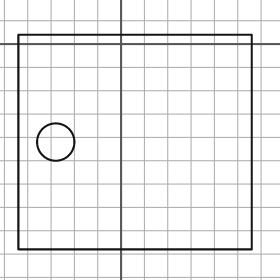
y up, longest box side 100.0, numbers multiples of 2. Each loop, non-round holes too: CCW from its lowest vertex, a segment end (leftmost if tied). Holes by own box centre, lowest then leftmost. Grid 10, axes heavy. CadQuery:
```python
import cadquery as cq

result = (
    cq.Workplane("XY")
    .moveTo(-44.0, -88.0)
    .lineTo(56.0, -88.0)
    .lineTo(56.0, 4.0)
    .lineTo(-44.0, 4.0)
    .close()
    .moveTo(-28.0, -42.0)
    .circle(8.0)
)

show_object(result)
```